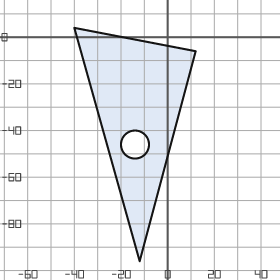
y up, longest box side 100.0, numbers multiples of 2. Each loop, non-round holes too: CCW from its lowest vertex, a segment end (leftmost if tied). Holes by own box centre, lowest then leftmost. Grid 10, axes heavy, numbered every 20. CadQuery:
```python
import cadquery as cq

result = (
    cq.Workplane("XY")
    .moveTo(-12.0, -96.0)
    .lineTo(12.0, -6.0)
    .lineTo(-40.0, 4.0)
    .close()
    .moveTo(-14.0, -46.0)
    .circle(6.0)
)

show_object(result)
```